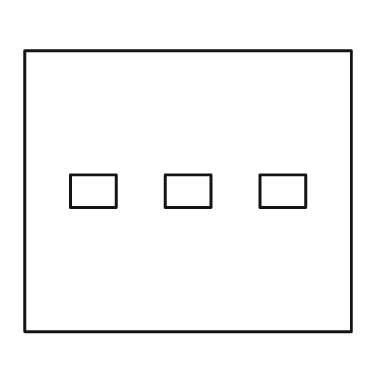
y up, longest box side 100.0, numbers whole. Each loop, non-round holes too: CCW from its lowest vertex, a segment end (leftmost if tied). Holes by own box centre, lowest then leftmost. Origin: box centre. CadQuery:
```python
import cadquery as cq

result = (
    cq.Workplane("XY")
    .moveTo(-50.0, -43.0)
    .lineTo(50.0, -43.0)
    .lineTo(50.0, 43.0)
    .lineTo(-50.0, 43.0)
    .close()
    .moveTo(-36.0, -5.0)
    .lineTo(-22.0, -5.0)
    .lineTo(-22.0, 5.0)
    .lineTo(-36.0, 5.0)
    .close()
    .moveTo(-7.0, -5.0)
    .lineTo(7.0, -5.0)
    .lineTo(7.0, 5.0)
    .lineTo(-7.0, 5.0)
    .close()
    .moveTo(22.0, -5.0)
    .lineTo(36.0, -5.0)
    .lineTo(36.0, 5.0)
    .lineTo(22.0, 5.0)
    .close()
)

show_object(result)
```